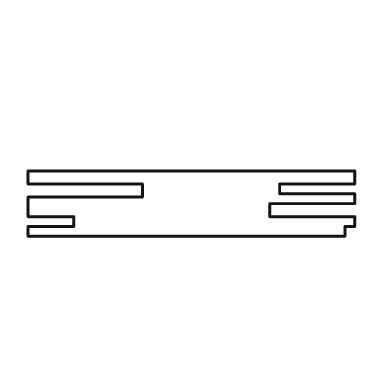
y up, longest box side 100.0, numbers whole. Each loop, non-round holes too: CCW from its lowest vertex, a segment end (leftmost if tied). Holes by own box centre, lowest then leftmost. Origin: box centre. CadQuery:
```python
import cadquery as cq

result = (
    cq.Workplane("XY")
    .moveTo(-50.0, -10.0)
    .lineTo(47.0, -10.0)
    .lineTo(47.0, -7.0)
    .lineTo(50.0, -7.0)
    .lineTo(50.0, -4.0)
    .lineTo(24.0, -4.0)
    .lineTo(24.0, 0.0)
    .lineTo(50.0, 0.0)
    .lineTo(50.0, 3.0)
    .lineTo(27.0, 3.0)
    .lineTo(27.0, 6.0)
    .lineTo(50.0, 6.0)
    .lineTo(50.0, 10.0)
    .lineTo(-50.0, 10.0)
    .lineTo(-50.0, 6.0)
    .lineTo(-15.0, 6.0)
    .lineTo(-15.0, 2.0)
    .lineTo(-50.0, 2.0)
    .lineTo(-50.0, -4.0)
    .lineTo(-36.0, -4.0)
    .lineTo(-36.0, -7.0)
    .lineTo(-50.0, -7.0)
    .close()
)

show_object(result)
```